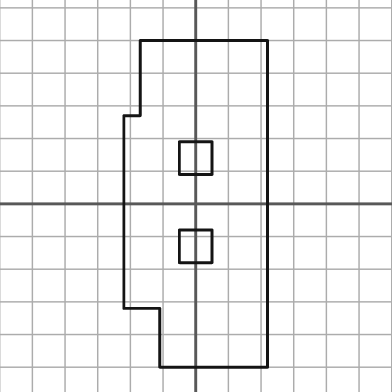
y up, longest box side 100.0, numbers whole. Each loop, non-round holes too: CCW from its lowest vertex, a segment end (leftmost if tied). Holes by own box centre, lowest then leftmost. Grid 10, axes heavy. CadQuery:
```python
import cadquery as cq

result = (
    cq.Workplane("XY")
    .moveTo(-11.0, -50.0)
    .lineTo(22.0, -50.0)
    .lineTo(22.0, 50.0)
    .lineTo(-17.0, 50.0)
    .lineTo(-17.0, 27.0)
    .lineTo(-22.0, 27.0)
    .lineTo(-22.0, -32.0)
    .lineTo(-11.0, -32.0)
    .close()
    .moveTo(-5.0, -18.0)
    .lineTo(5.0, -18.0)
    .lineTo(5.0, -8.0)
    .lineTo(-5.0, -8.0)
    .close()
    .moveTo(-5.0, 9.0)
    .lineTo(5.0, 9.0)
    .lineTo(5.0, 19.0)
    .lineTo(-5.0, 19.0)
    .close()
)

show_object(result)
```